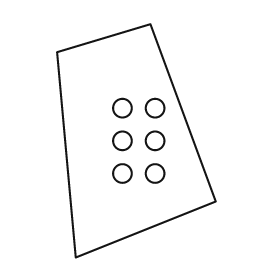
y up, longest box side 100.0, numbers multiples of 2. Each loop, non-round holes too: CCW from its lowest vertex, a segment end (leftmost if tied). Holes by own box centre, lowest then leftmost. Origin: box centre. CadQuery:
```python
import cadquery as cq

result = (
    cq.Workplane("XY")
    .moveTo(-26.0, -50.0)
    .lineTo(34.0, -26.0)
    .lineTo(6.0, 50.0)
    .lineTo(-34.0, 38.0)
    .close()
    .moveTo(-6.0, -14.0)
    .circle(4.0)
    .moveTo(8.0, -14.0)
    .circle(4.0)
    .moveTo(-6.0, 0.0)
    .circle(4.0)
    .moveTo(8.0, 0.0)
    .circle(4.0)
    .moveTo(-6.0, 14.0)
    .circle(4.0)
    .moveTo(8.0, 14.0)
    .circle(4.0)
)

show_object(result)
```